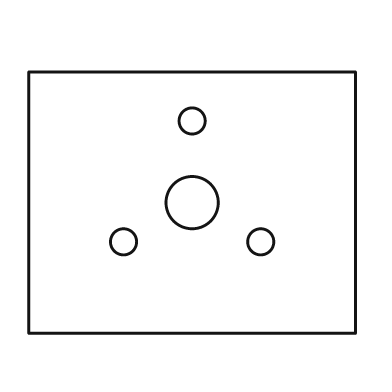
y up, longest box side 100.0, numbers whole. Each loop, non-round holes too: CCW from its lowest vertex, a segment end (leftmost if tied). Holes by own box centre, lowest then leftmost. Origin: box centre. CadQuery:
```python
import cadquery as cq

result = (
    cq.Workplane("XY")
    .moveTo(-50.0, -40.0)
    .lineTo(50.0, -40.0)
    .lineTo(50.0, 40.0)
    .lineTo(-50.0, 40.0)
    .close()
    .moveTo(-21.0, -12.0)
    .circle(4.0)
    .moveTo(21.0, -12.0)
    .circle(4.0)
    .moveTo(0.0, 0.0)
    .circle(8.0)
    .moveTo(0.0, 25.0)
    .circle(4.0)
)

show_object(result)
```